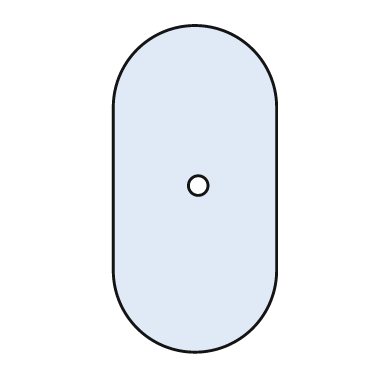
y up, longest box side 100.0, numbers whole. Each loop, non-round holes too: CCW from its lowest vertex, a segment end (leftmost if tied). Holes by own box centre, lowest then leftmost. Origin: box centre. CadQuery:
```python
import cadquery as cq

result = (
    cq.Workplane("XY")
    .moveTo(-25.0, -25.0)
    .threePointArc((0.0, -50.0), (25.0, -25.0))
    .lineTo(25.0, 25.0)
    .threePointArc((0.0, 50.0), (-25.0, 25.0))
    .close()
    .moveTo(1.0, 1.0)
    .circle(3.0)
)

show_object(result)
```